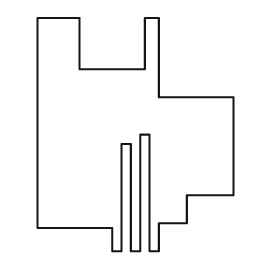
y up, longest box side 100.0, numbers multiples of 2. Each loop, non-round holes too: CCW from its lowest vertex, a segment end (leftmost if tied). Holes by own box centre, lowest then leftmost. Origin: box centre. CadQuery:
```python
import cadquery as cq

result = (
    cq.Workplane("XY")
    .moveTo(-10.0, -50.0)
    .lineTo(-6.0, -50.0)
    .lineTo(-6.0, -4.0)
    .lineTo(-2.0, -4.0)
    .lineTo(-2.0, -50.0)
    .lineTo(2.0, -50.0)
    .lineTo(2.0, 0.0)
    .lineTo(6.0, 0.0)
    .lineTo(6.0, -50.0)
    .lineTo(10.0, -50.0)
    .lineTo(10.0, -38.0)
    .lineTo(22.0, -38.0)
    .lineTo(22.0, -26.0)
    .lineTo(42.0, -26.0)
    .lineTo(42.0, 16.0)
    .lineTo(10.0, 16.0)
    .lineTo(10.0, 50.0)
    .lineTo(4.0, 50.0)
    .lineTo(4.0, 28.0)
    .lineTo(-24.0, 28.0)
    .lineTo(-24.0, 50.0)
    .lineTo(-42.0, 50.0)
    .lineTo(-42.0, -40.0)
    .lineTo(-10.0, -40.0)
    .close()
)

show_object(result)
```